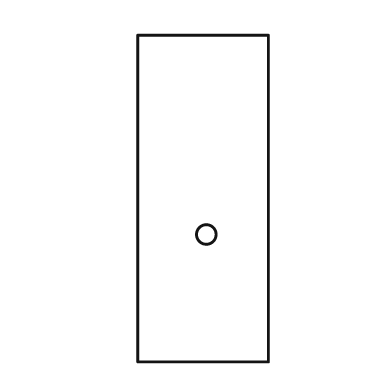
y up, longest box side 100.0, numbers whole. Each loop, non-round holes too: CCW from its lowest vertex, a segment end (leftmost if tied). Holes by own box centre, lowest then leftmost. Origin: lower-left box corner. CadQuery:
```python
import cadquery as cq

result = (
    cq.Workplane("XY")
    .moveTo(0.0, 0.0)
    .lineTo(40.0, 0.0)
    .lineTo(40.0, 100.0)
    .lineTo(0.0, 100.0)
    .close()
    .moveTo(21.0, 39.0)
    .circle(3.0)
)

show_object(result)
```